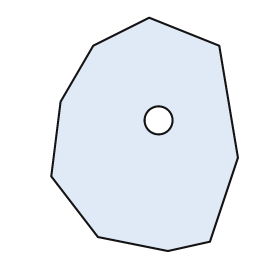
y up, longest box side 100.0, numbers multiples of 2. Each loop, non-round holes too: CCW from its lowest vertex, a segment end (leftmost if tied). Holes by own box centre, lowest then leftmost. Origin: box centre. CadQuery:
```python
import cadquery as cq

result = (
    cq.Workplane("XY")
    .moveTo(10.0, -50.0)
    .lineTo(28.0, -46.0)
    .lineTo(40.0, -10.0)
    .lineTo(32.0, 38.0)
    .lineTo(2.0, 50.0)
    .lineTo(-22.0, 38.0)
    .lineTo(-36.0, 14.0)
    .lineTo(-40.0, -18.0)
    .lineTo(-20.0, -44.0)
    .close()
    .moveTo(6.0, 6.0)
    .circle(6.0)
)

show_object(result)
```